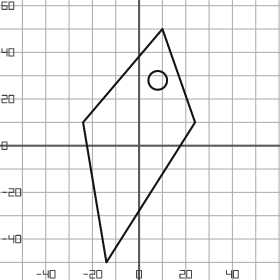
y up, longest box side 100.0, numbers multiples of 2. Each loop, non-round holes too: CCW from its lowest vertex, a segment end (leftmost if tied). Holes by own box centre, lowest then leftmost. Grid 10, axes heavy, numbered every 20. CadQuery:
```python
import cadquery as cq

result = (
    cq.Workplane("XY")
    .moveTo(-14.0, -50.0)
    .lineTo(24.0, 10.0)
    .lineTo(10.0, 50.0)
    .lineTo(-24.0, 10.0)
    .close()
    .moveTo(8.0, 28.0)
    .circle(4.0)
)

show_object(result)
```